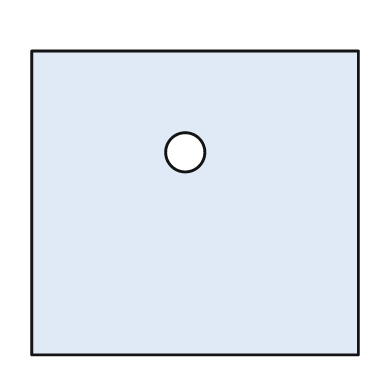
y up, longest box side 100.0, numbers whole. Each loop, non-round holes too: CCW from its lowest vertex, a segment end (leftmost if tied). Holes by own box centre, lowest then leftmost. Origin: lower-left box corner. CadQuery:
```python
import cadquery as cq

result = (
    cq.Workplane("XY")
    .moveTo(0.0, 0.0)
    .lineTo(100.0, 0.0)
    .lineTo(100.0, 93.0)
    .lineTo(0.0, 93.0)
    .close()
    .moveTo(47.0, 62.0)
    .circle(6.0)
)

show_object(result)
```